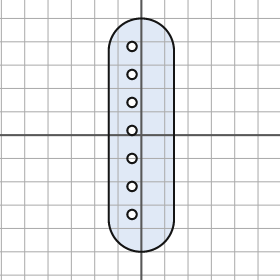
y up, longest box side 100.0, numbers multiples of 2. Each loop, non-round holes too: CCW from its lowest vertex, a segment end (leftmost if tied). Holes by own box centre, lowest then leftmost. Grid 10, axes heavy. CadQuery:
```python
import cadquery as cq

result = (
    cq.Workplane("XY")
    .moveTo(-14.0, -36.0)
    .threePointArc((0.0, -50.0), (14.0, -36.0))
    .lineTo(14.0, 36.0)
    .threePointArc((0.0, 50.0), (-14.0, 36.0))
    .close()
    .moveTo(-4.0, -34.0)
    .circle(2.0)
    .moveTo(-4.0, -22.0)
    .circle(2.0)
    .moveTo(-4.0, -10.0)
    .circle(2.0)
    .moveTo(-4.0, 2.0)
    .circle(2.0)
    .moveTo(-4.0, 14.0)
    .circle(2.0)
    .moveTo(-4.0, 26.0)
    .circle(2.0)
    .moveTo(-4.0, 38.0)
    .circle(2.0)
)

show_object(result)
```